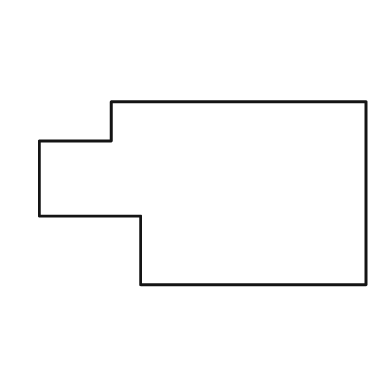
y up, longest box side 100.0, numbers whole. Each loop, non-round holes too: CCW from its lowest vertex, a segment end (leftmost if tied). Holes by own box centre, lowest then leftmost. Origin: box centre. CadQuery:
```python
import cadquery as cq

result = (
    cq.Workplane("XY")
    .moveTo(-19.0, -28.0)
    .lineTo(50.0, -28.0)
    .lineTo(50.0, 28.0)
    .lineTo(-28.0, 28.0)
    .lineTo(-28.0, 16.0)
    .lineTo(-50.0, 16.0)
    .lineTo(-50.0, -7.0)
    .lineTo(-19.0, -7.0)
    .close()
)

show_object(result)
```